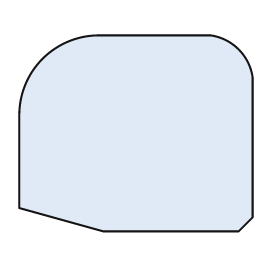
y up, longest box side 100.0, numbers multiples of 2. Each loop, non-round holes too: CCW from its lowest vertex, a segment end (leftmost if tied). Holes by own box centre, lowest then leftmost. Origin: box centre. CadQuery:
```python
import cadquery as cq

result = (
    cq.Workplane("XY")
    .moveTo(-14.0, -42.0)
    .lineTo(44.0, -42.0)
    .lineTo(50.0, -36.0)
    .lineTo(50.0, 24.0)
    .threePointArc((44.0, 36.0), (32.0, 42.0))
    .lineTo(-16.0, 42.0)
    .threePointArc((-40.0, 32.0), (-50.0, 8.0))
    .lineTo(-50.0, -32.0)
    .close()
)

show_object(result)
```